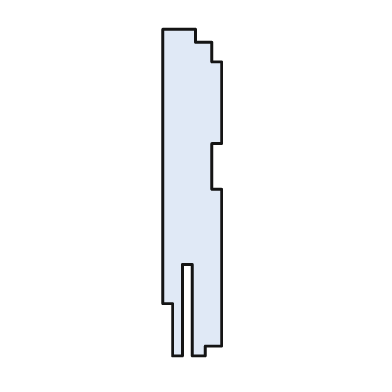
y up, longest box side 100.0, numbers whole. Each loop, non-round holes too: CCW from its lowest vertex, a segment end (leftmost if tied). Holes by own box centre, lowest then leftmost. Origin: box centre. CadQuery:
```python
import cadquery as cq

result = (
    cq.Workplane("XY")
    .moveTo(-6.0, -50.0)
    .lineTo(-3.0, -50.0)
    .lineTo(-3.0, -22.0)
    .lineTo(0.0, -22.0)
    .lineTo(0.0, -50.0)
    .lineTo(4.0, -50.0)
    .lineTo(4.0, -47.0)
    .lineTo(9.0, -47.0)
    .lineTo(9.0, 1.0)
    .lineTo(6.0, 1.0)
    .lineTo(6.0, 15.0)
    .lineTo(9.0, 15.0)
    .lineTo(9.0, 40.0)
    .lineTo(6.0, 40.0)
    .lineTo(6.0, 46.0)
    .lineTo(1.0, 46.0)
    .lineTo(1.0, 50.0)
    .lineTo(-9.0, 50.0)
    .lineTo(-9.0, -34.0)
    .lineTo(-6.0, -34.0)
    .close()
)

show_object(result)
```